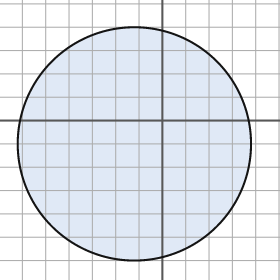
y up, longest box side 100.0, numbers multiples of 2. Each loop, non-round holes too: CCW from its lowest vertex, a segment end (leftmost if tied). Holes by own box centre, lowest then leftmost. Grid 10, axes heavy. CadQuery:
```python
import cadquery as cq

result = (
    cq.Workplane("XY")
    .moveTo(-12.0, -10.0)
    .circle(50.0)
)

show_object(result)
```